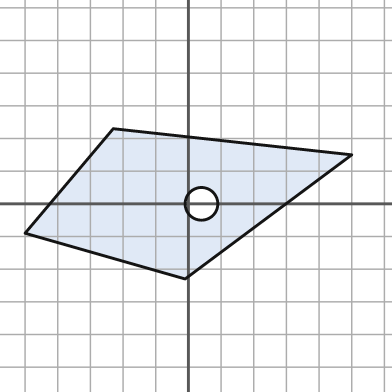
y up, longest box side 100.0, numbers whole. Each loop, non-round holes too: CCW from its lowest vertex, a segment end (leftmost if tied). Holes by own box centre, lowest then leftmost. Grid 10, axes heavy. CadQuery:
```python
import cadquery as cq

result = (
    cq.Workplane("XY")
    .moveTo(-1.0, -23.0)
    .lineTo(50.0, 15.0)
    .lineTo(-23.0, 23.0)
    .lineTo(-50.0, -9.0)
    .close()
    .moveTo(4.0, 0.0)
    .circle(5.0)
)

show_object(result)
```